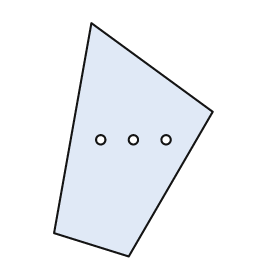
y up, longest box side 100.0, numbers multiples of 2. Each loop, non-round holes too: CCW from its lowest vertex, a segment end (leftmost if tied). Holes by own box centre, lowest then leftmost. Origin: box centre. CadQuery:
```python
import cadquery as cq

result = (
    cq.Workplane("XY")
    .moveTo(-2.0, -50.0)
    .lineTo(34.0, 12.0)
    .lineTo(-18.0, 50.0)
    .lineTo(-34.0, -40.0)
    .close()
    .moveTo(-14.0, 0.0)
    .circle(2.0)
    .moveTo(0.0, 0.0)
    .circle(2.0)
    .moveTo(14.0, 0.0)
    .circle(2.0)
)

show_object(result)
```